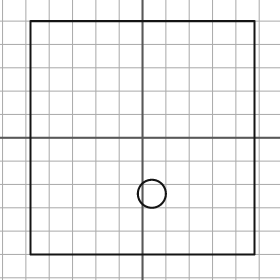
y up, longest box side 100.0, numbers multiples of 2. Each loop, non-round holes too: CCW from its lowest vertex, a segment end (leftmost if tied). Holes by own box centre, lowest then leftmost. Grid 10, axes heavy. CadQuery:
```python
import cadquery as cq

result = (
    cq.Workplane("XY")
    .moveTo(-48.0, -50.0)
    .lineTo(48.0, -50.0)
    .lineTo(48.0, 50.0)
    .lineTo(-48.0, 50.0)
    .close()
    .moveTo(4.0, -24.0)
    .circle(6.0)
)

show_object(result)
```